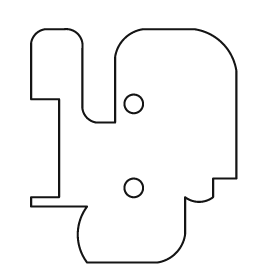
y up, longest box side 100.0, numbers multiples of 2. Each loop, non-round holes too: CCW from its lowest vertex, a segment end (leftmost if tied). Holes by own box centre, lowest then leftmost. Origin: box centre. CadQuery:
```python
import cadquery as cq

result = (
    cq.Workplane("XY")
    .moveTo(-20.0, -50.0)
    .lineTo(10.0, -50.0)
    .threePointArc((18.0, -46.0), (22.0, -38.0))
    .lineTo(22.0, -22.0)
    .threePointArc((28.0, -24.0), (34.0, -22.0))
    .lineTo(34.0, -14.0)
    .lineTo(44.0, -14.0)
    .lineTo(44.0, 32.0)
    .threePointArc((38.0, 44.0), (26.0, 50.0))
    .lineTo(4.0, 50.0)
    .threePointArc((-4.0, 46.0), (-8.0, 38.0))
    .lineTo(-8.0, 10.0)
    .lineTo(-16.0, 10.0)
    .threePointArc((-20.0, 12.0), (-22.0, 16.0))
    .lineTo(-22.0, 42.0)
    .threePointArc((-24.0, 48.0), (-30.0, 50.0))
    .lineTo(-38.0, 50.0)
    .threePointArc((-42.0, 48.0), (-44.0, 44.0))
    .lineTo(-44.0, 20.0)
    .lineTo(-32.0, 20.0)
    .lineTo(-32.0, -22.0)
    .lineTo(-44.0, -22.0)
    .lineTo(-44.0, -26.0)
    .lineTo(-20.0, -26.0)
    .threePointArc((-24.0, -38.0), (-20.0, -50.0))
    .close()
    .moveTo(0.0, -18.0)
    .circle(4.0)
    .moveTo(0.0, 18.0)
    .circle(4.0)
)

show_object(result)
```